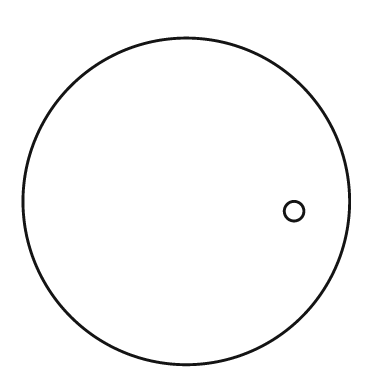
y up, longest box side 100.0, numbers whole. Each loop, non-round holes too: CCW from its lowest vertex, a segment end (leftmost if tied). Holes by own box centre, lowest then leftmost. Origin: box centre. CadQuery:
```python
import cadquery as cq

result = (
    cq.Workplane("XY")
    .moveTo(0.0, 0.0)
    .circle(50.0)
    .moveTo(33.0, -3.0)
    .circle(3.0)
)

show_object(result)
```